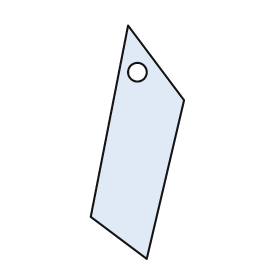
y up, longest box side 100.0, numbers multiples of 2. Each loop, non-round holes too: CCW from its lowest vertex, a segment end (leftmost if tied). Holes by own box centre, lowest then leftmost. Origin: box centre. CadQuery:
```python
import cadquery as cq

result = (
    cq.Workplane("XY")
    .moveTo(4.0, -50.0)
    .lineTo(20.0, 18.0)
    .lineTo(-4.0, 50.0)
    .lineTo(-20.0, -32.0)
    .close()
    .moveTo(0.0, 30.0)
    .circle(4.0)
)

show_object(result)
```